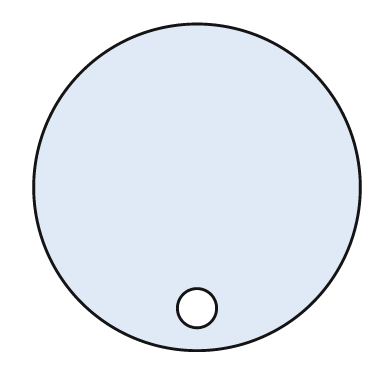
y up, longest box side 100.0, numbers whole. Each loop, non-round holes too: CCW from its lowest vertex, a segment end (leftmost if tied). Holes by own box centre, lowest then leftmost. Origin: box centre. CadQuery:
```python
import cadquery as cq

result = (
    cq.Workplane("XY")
    .moveTo(0.0, 0.0)
    .circle(50.0)
    .moveTo(0.0, -37.0)
    .circle(6.0)
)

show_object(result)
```